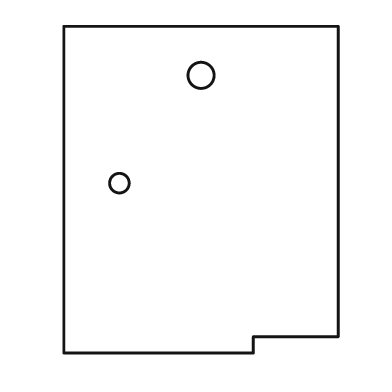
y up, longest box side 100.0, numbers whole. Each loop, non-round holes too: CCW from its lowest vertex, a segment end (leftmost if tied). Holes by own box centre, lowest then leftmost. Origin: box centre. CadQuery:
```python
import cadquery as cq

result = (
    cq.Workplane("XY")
    .moveTo(-42.0, -50.0)
    .lineTo(16.0, -50.0)
    .lineTo(16.0, -45.0)
    .lineTo(42.0, -45.0)
    .lineTo(42.0, 50.0)
    .lineTo(-42.0, 50.0)
    .close()
    .moveTo(-25.0, 2.0)
    .circle(3.0)
    .moveTo(0.0, 35.0)
    .circle(4.0)
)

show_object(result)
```